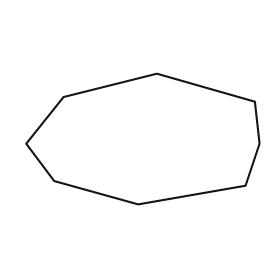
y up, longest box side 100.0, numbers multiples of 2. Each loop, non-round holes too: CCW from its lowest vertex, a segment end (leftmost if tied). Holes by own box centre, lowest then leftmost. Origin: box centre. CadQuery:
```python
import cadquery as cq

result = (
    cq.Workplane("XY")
    .moveTo(-2.0, -28.0)
    .lineTo(44.0, -20.0)
    .lineTo(50.0, -2.0)
    .lineTo(48.0, 16.0)
    .lineTo(6.0, 28.0)
    .lineTo(-34.0, 18.0)
    .lineTo(-50.0, -2.0)
    .lineTo(-38.0, -18.0)
    .close()
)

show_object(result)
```